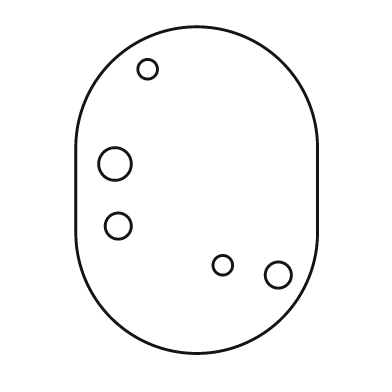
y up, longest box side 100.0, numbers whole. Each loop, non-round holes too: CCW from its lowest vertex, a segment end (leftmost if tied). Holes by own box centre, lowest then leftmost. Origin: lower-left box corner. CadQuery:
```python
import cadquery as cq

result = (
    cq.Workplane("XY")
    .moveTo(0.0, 37.0)
    .threePointArc((37.0, 0.0), (74.0, 37.0))
    .lineTo(74.0, 63.0)
    .threePointArc((37.0, 100.0), (0.0, 63.0))
    .close()
    .moveTo(62.0, 24.0)
    .circle(4.0)
    .moveTo(45.0, 27.0)
    .circle(3.0)
    .moveTo(13.0, 39.0)
    .circle(4.0)
    .moveTo(12.0, 58.0)
    .circle(5.0)
    .moveTo(22.0, 87.0)
    .circle(3.0)
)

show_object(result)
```